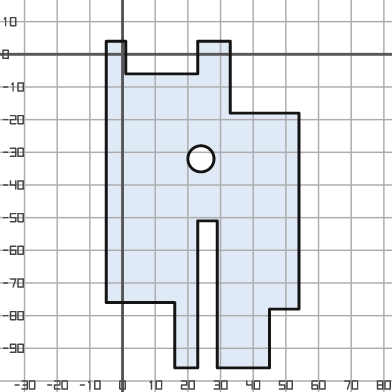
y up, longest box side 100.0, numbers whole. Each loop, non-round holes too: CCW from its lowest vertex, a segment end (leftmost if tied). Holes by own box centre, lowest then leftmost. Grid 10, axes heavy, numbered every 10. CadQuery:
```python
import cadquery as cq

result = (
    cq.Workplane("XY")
    .moveTo(16.0, -96.0)
    .lineTo(23.0, -96.0)
    .lineTo(23.0, -51.0)
    .lineTo(29.0, -51.0)
    .lineTo(29.0, -96.0)
    .lineTo(45.0, -96.0)
    .lineTo(45.0, -78.0)
    .lineTo(54.0, -78.0)
    .lineTo(54.0, -18.0)
    .lineTo(33.0, -18.0)
    .lineTo(33.0, 4.0)
    .lineTo(23.0, 4.0)
    .lineTo(23.0, -6.0)
    .lineTo(1.0, -6.0)
    .lineTo(1.0, 4.0)
    .lineTo(-5.0, 4.0)
    .lineTo(-5.0, -76.0)
    .lineTo(16.0, -76.0)
    .close()
    .moveTo(24.0, -32.0)
    .circle(4.0)
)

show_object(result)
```